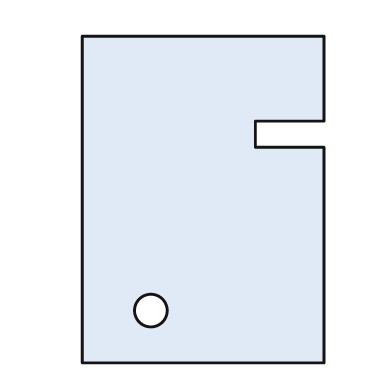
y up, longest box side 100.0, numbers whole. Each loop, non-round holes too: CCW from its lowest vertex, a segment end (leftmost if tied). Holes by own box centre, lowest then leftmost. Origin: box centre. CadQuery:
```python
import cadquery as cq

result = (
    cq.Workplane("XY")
    .moveTo(-37.0, -50.0)
    .lineTo(37.0, -50.0)
    .lineTo(37.0, 16.0)
    .lineTo(16.0, 16.0)
    .lineTo(16.0, 24.0)
    .lineTo(37.0, 24.0)
    .lineTo(37.0, 50.0)
    .lineTo(-37.0, 50.0)
    .close()
    .moveTo(-16.0, -34.0)
    .circle(5.0)
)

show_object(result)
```